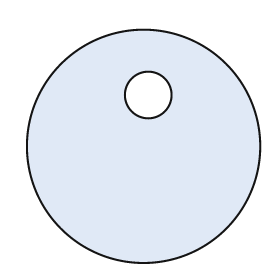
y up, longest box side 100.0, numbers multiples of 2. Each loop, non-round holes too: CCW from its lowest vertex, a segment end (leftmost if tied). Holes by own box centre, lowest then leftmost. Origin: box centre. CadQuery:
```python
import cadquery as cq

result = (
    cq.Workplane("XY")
    .moveTo(0.0, 0.0)
    .circle(50.0)
    .moveTo(2.0, 22.0)
    .circle(10.0)
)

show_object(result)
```